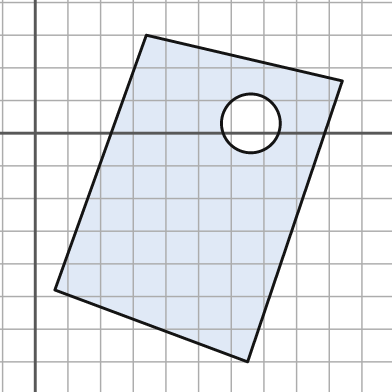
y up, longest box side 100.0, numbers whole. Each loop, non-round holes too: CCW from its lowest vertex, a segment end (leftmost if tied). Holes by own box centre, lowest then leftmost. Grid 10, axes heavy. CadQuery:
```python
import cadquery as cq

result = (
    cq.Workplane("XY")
    .moveTo(65.0, -70.0)
    .lineTo(94.0, 16.0)
    .lineTo(34.0, 30.0)
    .lineTo(6.0, -48.0)
    .close()
    .moveTo(66.0, 3.0)
    .circle(9.0)
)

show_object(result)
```